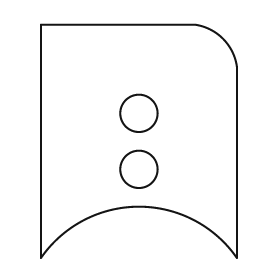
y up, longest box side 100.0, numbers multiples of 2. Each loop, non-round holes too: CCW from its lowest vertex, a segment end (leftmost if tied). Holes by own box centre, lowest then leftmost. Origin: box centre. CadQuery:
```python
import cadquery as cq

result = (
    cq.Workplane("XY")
    .moveTo(-42.0, -50.0)
    .threePointArc((0.0, -28.0), (42.0, -50.0))
    .lineTo(42.0, 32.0)
    .threePointArc((36.0, 44.0), (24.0, 50.0))
    .lineTo(-42.0, 50.0)
    .close()
    .moveTo(0.0, -12.0)
    .circle(8.0)
    .moveTo(0.0, 12.0)
    .circle(8.0)
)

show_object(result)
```